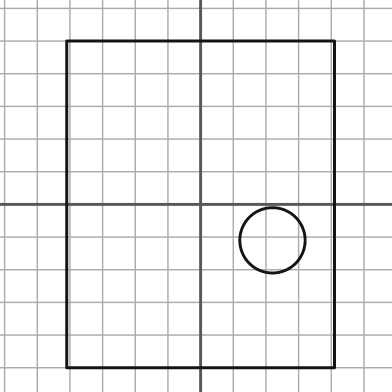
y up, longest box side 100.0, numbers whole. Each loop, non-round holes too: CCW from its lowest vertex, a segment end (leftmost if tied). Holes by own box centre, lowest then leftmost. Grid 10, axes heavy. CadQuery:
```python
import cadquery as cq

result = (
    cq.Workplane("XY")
    .moveTo(-41.0, -50.0)
    .lineTo(41.0, -50.0)
    .lineTo(41.0, 50.0)
    .lineTo(-41.0, 50.0)
    .close()
    .moveTo(22.0, -11.0)
    .circle(10.0)
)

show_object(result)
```